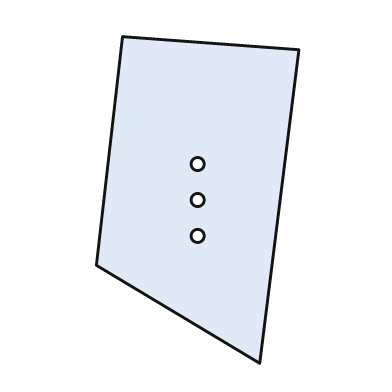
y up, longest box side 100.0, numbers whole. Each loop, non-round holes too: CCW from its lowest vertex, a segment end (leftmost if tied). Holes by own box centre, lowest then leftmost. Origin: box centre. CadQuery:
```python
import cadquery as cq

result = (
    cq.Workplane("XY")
    .moveTo(19.0, -50.0)
    .lineTo(31.0, 46.0)
    .lineTo(-23.0, 50.0)
    .lineTo(-31.0, -20.0)
    .close()
    .moveTo(0.0, -11.0)
    .circle(2.0)
    .moveTo(0.0, 0.0)
    .circle(2.0)
    .moveTo(0.0, 11.0)
    .circle(2.0)
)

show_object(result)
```